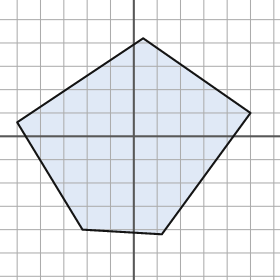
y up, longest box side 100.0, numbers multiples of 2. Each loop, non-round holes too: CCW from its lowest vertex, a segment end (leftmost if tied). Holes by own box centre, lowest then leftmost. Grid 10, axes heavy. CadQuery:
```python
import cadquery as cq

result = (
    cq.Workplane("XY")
    .moveTo(12.0, -42.0)
    .lineTo(50.0, 10.0)
    .lineTo(4.0, 42.0)
    .lineTo(-50.0, 6.0)
    .lineTo(-22.0, -40.0)
    .close()
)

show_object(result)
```